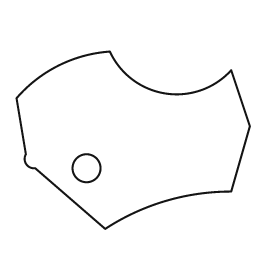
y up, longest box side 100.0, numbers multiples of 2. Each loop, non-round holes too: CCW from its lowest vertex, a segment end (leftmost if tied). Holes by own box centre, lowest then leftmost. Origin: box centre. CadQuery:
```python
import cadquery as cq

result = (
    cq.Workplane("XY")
    .moveTo(-12.0, -38.0)
    .threePointArc((14.0, -26.0), (42.0, -22.0))
    .lineTo(50.0, 6.0)
    .lineTo(42.0, 30.0)
    .threePointArc((14.0, 20.0), (-10.0, 38.0))
    .threePointArc((-32.0, 32.0), (-50.0, 18.0))
    .lineTo(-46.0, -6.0)
    .threePointArc((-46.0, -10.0), (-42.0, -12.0))
    .close()
    .moveTo(-20.0, -12.0)
    .circle(6.0)
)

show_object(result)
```